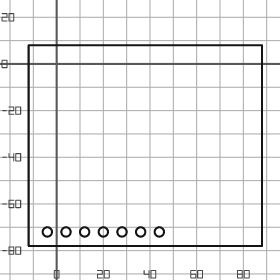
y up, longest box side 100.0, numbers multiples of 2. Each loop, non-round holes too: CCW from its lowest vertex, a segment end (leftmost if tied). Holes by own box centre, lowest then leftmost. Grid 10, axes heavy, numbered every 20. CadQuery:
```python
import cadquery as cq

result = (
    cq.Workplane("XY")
    .moveTo(-12.0, -78.0)
    .lineTo(88.0, -78.0)
    .lineTo(88.0, 8.0)
    .lineTo(-12.0, 8.0)
    .close()
    .moveTo(-4.0, -72.0)
    .circle(2.0)
    .moveTo(4.0, -72.0)
    .circle(2.0)
    .moveTo(12.0, -72.0)
    .circle(2.0)
    .moveTo(20.0, -72.0)
    .circle(2.0)
    .moveTo(28.0, -72.0)
    .circle(2.0)
    .moveTo(36.0, -72.0)
    .circle(2.0)
    .moveTo(44.0, -72.0)
    .circle(2.0)
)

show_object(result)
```